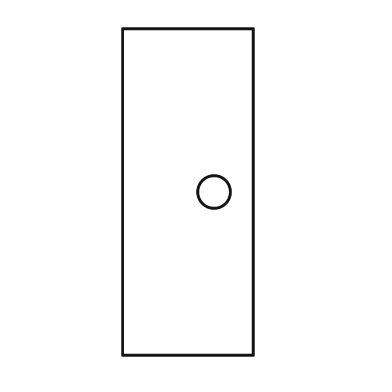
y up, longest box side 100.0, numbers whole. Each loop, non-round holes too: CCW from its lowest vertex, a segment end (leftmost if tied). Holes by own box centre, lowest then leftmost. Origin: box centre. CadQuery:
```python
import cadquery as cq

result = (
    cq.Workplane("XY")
    .moveTo(-20.0, -50.0)
    .lineTo(20.0, -50.0)
    .lineTo(20.0, 50.0)
    .lineTo(-20.0, 50.0)
    .close()
    .moveTo(8.0, 0.0)
    .circle(5.0)
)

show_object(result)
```